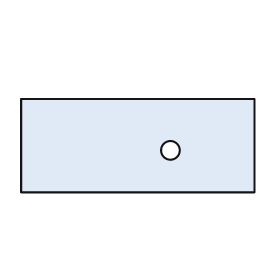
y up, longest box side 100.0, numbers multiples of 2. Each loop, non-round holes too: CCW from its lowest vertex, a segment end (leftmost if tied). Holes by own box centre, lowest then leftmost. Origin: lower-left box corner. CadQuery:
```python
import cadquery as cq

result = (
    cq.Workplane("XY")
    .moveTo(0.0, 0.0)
    .lineTo(100.0, 0.0)
    .lineTo(100.0, 40.0)
    .lineTo(0.0, 40.0)
    .close()
    .moveTo(64.0, 18.0)
    .circle(4.0)
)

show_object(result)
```